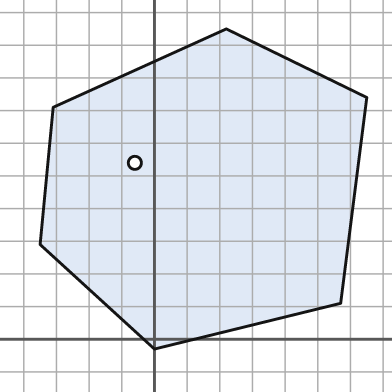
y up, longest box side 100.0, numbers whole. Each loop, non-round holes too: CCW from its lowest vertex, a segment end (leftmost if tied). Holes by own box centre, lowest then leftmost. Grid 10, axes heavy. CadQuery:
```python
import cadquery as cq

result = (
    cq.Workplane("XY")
    .moveTo(0.0, -3.0)
    .lineTo(57.0, 11.0)
    .lineTo(65.0, 74.0)
    .lineTo(22.0, 95.0)
    .lineTo(-31.0, 71.0)
    .lineTo(-35.0, 29.0)
    .close()
    .moveTo(-6.0, 54.0)
    .circle(2.0)
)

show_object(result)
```